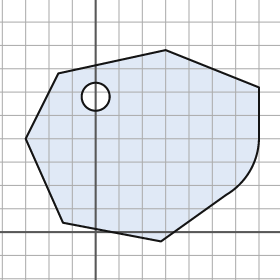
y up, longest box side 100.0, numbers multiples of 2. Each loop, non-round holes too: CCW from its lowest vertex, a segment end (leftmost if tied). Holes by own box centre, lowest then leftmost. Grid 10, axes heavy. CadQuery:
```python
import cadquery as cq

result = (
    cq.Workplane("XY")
    .moveTo(28.0, -4.0)
    .lineTo(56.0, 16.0)
    .threePointArc((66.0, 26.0), (70.0, 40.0))
    .lineTo(70.0, 62.0)
    .lineTo(30.0, 78.0)
    .lineTo(-16.0, 68.0)
    .lineTo(-30.0, 40.0)
    .lineTo(-14.0, 4.0)
    .close()
    .moveTo(0.0, 58.0)
    .circle(6.0)
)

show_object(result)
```